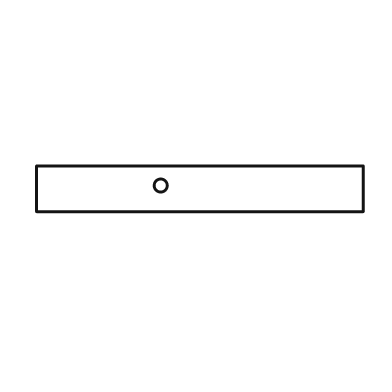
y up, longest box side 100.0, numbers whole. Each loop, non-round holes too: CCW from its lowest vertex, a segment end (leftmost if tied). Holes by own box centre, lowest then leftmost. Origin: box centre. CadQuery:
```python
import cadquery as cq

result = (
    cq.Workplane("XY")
    .moveTo(-50.0, -7.0)
    .lineTo(50.0, -7.0)
    .lineTo(50.0, 7.0)
    .lineTo(-50.0, 7.0)
    .close()
    .moveTo(-12.0, 1.0)
    .circle(2.0)
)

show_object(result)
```